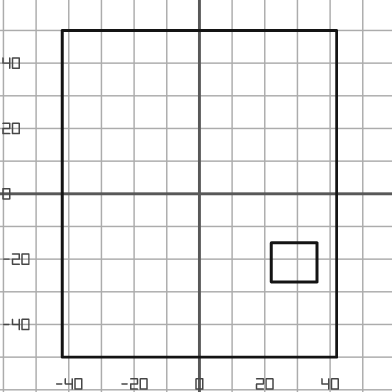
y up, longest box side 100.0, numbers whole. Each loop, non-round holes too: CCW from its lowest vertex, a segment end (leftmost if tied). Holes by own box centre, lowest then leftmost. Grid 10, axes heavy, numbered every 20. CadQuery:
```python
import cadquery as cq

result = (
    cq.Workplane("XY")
    .moveTo(-42.0, -50.0)
    .lineTo(42.0, -50.0)
    .lineTo(42.0, 50.0)
    .lineTo(-42.0, 50.0)
    .close()
    .moveTo(22.0, -27.0)
    .lineTo(36.0, -27.0)
    .lineTo(36.0, -15.0)
    .lineTo(22.0, -15.0)
    .close()
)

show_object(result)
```